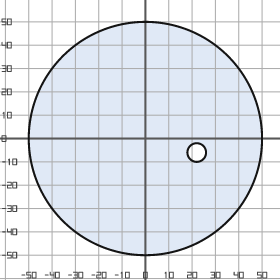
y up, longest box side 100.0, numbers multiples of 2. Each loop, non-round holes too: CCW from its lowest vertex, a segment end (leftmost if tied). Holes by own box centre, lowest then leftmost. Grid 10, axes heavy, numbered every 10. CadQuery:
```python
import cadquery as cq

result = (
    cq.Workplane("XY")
    .moveTo(0.0, 0.0)
    .circle(50.0)
    .moveTo(22.0, -6.0)
    .circle(4.0)
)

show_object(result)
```